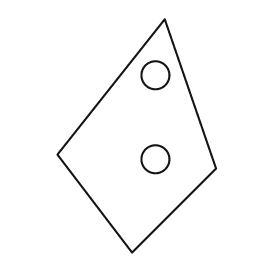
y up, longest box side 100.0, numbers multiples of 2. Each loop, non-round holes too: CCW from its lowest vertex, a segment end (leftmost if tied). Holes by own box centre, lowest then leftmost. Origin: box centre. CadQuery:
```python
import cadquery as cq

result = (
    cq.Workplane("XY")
    .moveTo(-2.0, -50.0)
    .lineTo(34.0, -14.0)
    .lineTo(12.0, 50.0)
    .lineTo(-34.0, -8.0)
    .close()
    .moveTo(8.0, -10.0)
    .circle(6.0)
    .moveTo(8.0, 26.0)
    .circle(6.0)
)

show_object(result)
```